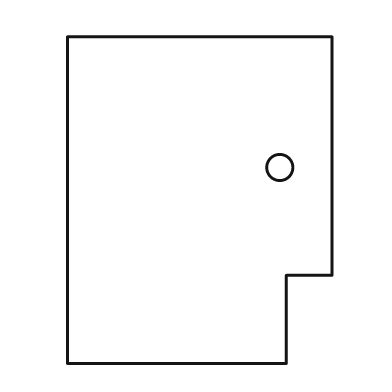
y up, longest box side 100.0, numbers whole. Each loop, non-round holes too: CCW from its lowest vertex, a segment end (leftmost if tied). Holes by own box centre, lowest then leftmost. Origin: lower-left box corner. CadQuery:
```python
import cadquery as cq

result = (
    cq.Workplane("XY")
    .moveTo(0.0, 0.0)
    .lineTo(67.0, 0.0)
    .lineTo(67.0, 27.0)
    .lineTo(81.0, 27.0)
    .lineTo(81.0, 100.0)
    .lineTo(0.0, 100.0)
    .close()
    .moveTo(65.0, 60.0)
    .circle(4.0)
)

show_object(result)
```